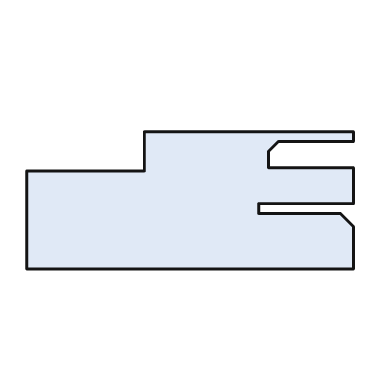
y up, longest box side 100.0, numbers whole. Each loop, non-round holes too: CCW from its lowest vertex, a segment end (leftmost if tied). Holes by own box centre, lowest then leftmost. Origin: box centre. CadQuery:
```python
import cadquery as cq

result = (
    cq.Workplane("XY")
    .moveTo(-50.0, -21.0)
    .lineTo(50.0, -21.0)
    .lineTo(50.0, -8.0)
    .lineTo(46.0, -4.0)
    .lineTo(21.0, -4.0)
    .lineTo(21.0, -1.0)
    .lineTo(50.0, -1.0)
    .lineTo(50.0, 10.0)
    .lineTo(24.0, 10.0)
    .lineTo(24.0, 15.0)
    .lineTo(27.0, 18.0)
    .lineTo(50.0, 18.0)
    .lineTo(50.0, 21.0)
    .lineTo(-14.0, 21.0)
    .lineTo(-14.0, 9.0)
    .lineTo(-50.0, 9.0)
    .close()
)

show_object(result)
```